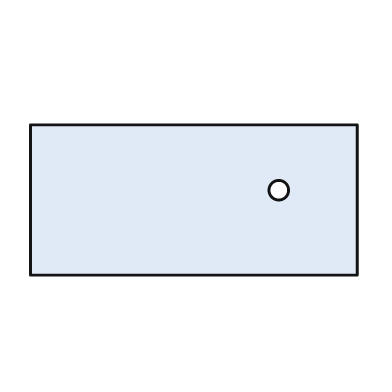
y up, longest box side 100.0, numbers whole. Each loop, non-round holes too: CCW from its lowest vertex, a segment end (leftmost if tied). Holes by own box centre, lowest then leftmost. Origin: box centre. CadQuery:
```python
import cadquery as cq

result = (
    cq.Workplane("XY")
    .moveTo(-50.0, -23.0)
    .lineTo(50.0, -23.0)
    .lineTo(50.0, 23.0)
    .lineTo(-50.0, 23.0)
    .close()
    .moveTo(26.0, 3.0)
    .circle(3.0)
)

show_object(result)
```